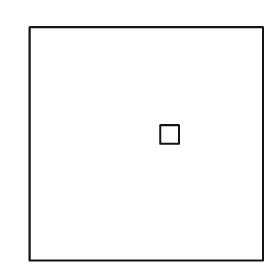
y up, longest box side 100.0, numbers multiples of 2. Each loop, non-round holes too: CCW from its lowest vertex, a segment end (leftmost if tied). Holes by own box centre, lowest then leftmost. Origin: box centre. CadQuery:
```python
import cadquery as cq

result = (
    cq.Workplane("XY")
    .moveTo(-50.0, -50.0)
    .lineTo(50.0, -50.0)
    .lineTo(50.0, 50.0)
    .lineTo(-50.0, 50.0)
    .close()
    .moveTo(6.0, 0.0)
    .lineTo(14.0, 0.0)
    .lineTo(14.0, 8.0)
    .lineTo(6.0, 8.0)
    .close()
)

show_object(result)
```